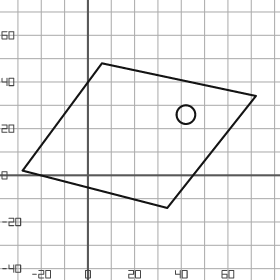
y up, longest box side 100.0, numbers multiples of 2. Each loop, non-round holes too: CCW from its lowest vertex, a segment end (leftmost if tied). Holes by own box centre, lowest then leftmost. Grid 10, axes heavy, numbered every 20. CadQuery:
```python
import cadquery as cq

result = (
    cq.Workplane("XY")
    .moveTo(34.0, -14.0)
    .lineTo(72.0, 34.0)
    .lineTo(6.0, 48.0)
    .lineTo(-28.0, 2.0)
    .close()
    .moveTo(42.0, 26.0)
    .circle(4.0)
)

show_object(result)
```